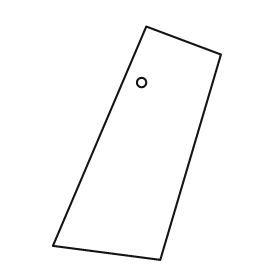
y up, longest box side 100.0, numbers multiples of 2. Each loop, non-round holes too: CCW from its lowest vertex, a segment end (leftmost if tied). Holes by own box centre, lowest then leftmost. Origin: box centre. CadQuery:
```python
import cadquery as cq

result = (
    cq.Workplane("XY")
    .moveTo(10.0, -50.0)
    .lineTo(36.0, 38.0)
    .lineTo(4.0, 50.0)
    .lineTo(-36.0, -44.0)
    .close()
    .moveTo(2.0, 26.0)
    .circle(2.0)
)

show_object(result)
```